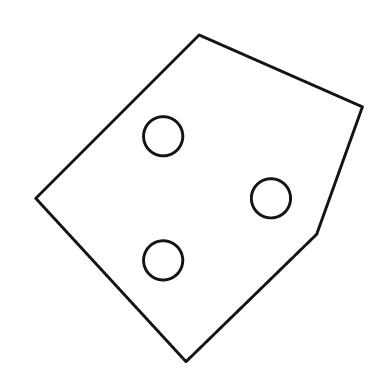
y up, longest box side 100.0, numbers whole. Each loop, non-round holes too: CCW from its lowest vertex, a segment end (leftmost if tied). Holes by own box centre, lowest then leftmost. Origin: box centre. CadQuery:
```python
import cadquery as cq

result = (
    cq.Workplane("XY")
    .moveTo(-4.0, -50.0)
    .lineTo(36.0, -11.0)
    .lineTo(50.0, 28.0)
    .lineTo(0.0, 50.0)
    .lineTo(-50.0, 0.0)
    .close()
    .moveTo(-11.0, -19.0)
    .circle(6.0)
    .moveTo(22.0, 0.0)
    .circle(6.0)
    .moveTo(-11.0, 19.0)
    .circle(6.0)
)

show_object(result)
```